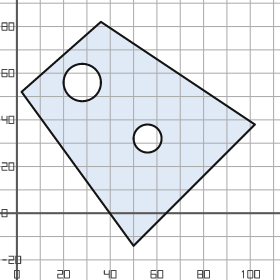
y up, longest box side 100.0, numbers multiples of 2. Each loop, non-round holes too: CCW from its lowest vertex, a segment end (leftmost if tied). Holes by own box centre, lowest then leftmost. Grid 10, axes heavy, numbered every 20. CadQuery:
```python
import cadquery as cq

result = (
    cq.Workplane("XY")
    .moveTo(50.0, -14.0)
    .lineTo(102.0, 38.0)
    .lineTo(36.0, 82.0)
    .lineTo(2.0, 52.0)
    .close()
    .moveTo(56.0, 32.0)
    .circle(6.0)
    .moveTo(28.0, 56.0)
    .circle(8.0)
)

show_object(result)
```